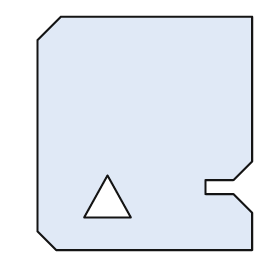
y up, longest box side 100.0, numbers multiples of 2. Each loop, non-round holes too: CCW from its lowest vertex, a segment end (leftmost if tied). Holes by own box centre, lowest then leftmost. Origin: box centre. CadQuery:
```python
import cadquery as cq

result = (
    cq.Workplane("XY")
    .moveTo(-38.0, -50.0)
    .lineTo(46.0, -50.0)
    .lineTo(46.0, -34.0)
    .lineTo(38.0, -26.0)
    .lineTo(26.0, -26.0)
    .lineTo(26.0, -20.0)
    .lineTo(38.0, -20.0)
    .lineTo(46.0, -12.0)
    .lineTo(46.0, 50.0)
    .lineTo(-36.0, 50.0)
    .lineTo(-46.0, 40.0)
    .lineTo(-46.0, -42.0)
    .close()
    .moveTo(-26.0, -36.0)
    .lineTo(-6.0, -36.0)
    .lineTo(-16.0, -18.0)
    .close()
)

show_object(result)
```